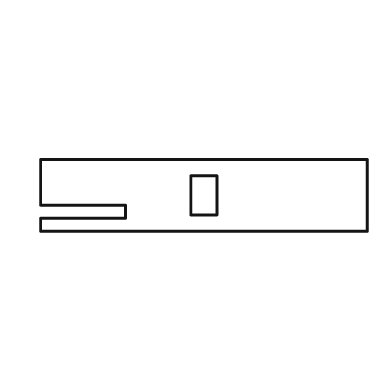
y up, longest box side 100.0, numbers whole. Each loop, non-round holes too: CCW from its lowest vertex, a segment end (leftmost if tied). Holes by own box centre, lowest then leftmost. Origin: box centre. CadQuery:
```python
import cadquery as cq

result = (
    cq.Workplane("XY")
    .moveTo(-50.0, -11.0)
    .lineTo(50.0, -11.0)
    .lineTo(50.0, 11.0)
    .lineTo(-50.0, 11.0)
    .lineTo(-50.0, -3.0)
    .lineTo(-24.0, -3.0)
    .lineTo(-24.0, -7.0)
    .lineTo(-50.0, -7.0)
    .close()
    .moveTo(-4.0, -6.0)
    .lineTo(4.0, -6.0)
    .lineTo(4.0, 6.0)
    .lineTo(-4.0, 6.0)
    .close()
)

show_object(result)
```